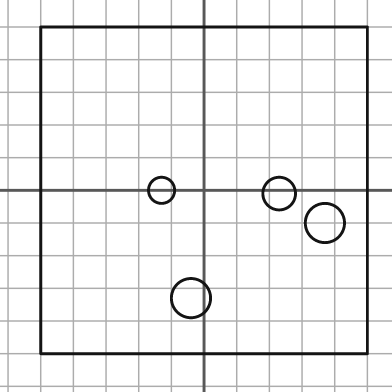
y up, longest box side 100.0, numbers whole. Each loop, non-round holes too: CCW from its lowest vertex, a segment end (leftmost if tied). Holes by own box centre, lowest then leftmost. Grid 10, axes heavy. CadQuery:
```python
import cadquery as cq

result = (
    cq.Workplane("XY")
    .moveTo(-50.0, -50.0)
    .lineTo(50.0, -50.0)
    .lineTo(50.0, 50.0)
    .lineTo(-50.0, 50.0)
    .close()
    .moveTo(-4.0, -33.0)
    .circle(6.0)
    .moveTo(37.0, -10.0)
    .circle(6.0)
    .moveTo(23.0, -1.0)
    .circle(5.0)
    .moveTo(-13.0, 0.0)
    .circle(4.0)
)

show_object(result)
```